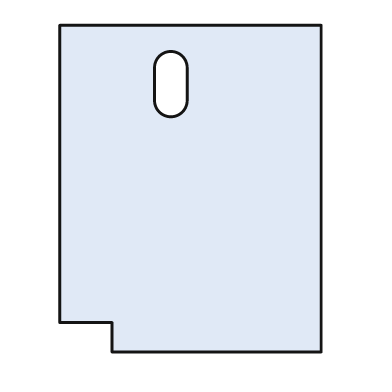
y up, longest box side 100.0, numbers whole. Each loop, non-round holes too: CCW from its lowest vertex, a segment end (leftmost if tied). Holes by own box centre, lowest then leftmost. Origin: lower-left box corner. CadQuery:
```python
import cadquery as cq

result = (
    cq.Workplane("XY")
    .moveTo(16.0, 0.0)
    .lineTo(80.0, 0.0)
    .lineTo(80.0, 100.0)
    .lineTo(0.0, 100.0)
    .lineTo(0.0, 9.0)
    .lineTo(16.0, 9.0)
    .close()
    .moveTo(29.0, 77.0)
    .threePointArc((34.0, 72.0), (39.0, 77.0))
    .lineTo(39.0, 87.0)
    .threePointArc((34.0, 92.0), (29.0, 87.0))
    .close()
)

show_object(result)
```